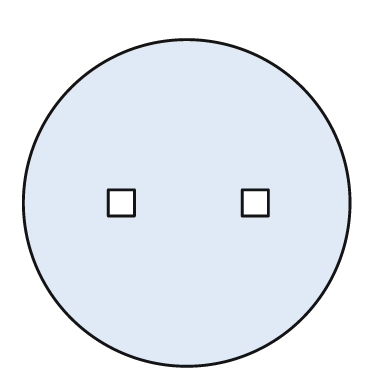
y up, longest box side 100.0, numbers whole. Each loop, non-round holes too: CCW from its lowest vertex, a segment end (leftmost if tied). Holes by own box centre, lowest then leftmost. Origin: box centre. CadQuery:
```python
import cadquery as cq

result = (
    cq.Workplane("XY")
    .moveTo(0.0, 0.0)
    .circle(50.0)
    .moveTo(-24.0, -4.0)
    .lineTo(-16.0, -4.0)
    .lineTo(-16.0, 4.0)
    .lineTo(-24.0, 4.0)
    .close()
    .moveTo(17.0, -4.0)
    .lineTo(25.0, -4.0)
    .lineTo(25.0, 4.0)
    .lineTo(17.0, 4.0)
    .close()
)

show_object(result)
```